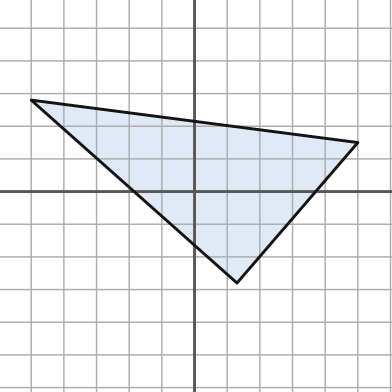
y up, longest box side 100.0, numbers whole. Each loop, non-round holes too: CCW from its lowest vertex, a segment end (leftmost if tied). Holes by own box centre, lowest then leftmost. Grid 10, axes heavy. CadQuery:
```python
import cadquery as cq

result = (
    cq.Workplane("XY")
    .moveTo(13.0, -28.0)
    .lineTo(50.0, 15.0)
    .lineTo(-50.0, 28.0)
    .close()
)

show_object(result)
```